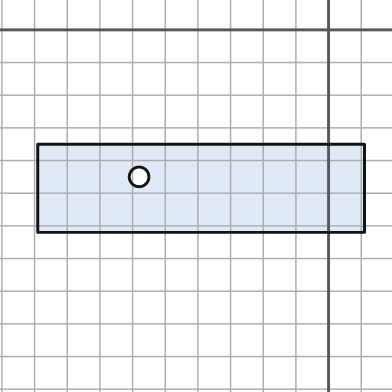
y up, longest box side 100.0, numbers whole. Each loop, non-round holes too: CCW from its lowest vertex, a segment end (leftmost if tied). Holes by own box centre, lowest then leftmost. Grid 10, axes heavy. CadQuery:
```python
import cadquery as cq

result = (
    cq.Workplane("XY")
    .moveTo(-89.0, -62.0)
    .lineTo(11.0, -62.0)
    .lineTo(11.0, -35.0)
    .lineTo(-89.0, -35.0)
    .close()
    .moveTo(-58.0, -45.0)
    .circle(3.0)
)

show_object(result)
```